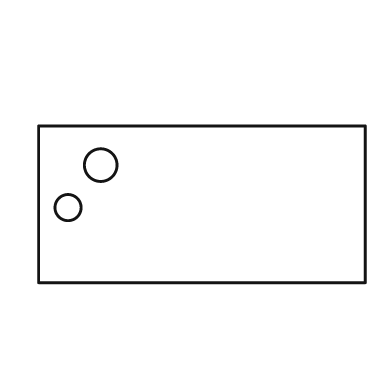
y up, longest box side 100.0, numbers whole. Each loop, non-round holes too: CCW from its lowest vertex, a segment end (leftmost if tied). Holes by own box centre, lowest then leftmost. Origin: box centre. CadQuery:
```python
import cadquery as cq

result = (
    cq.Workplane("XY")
    .moveTo(-50.0, -24.0)
    .lineTo(50.0, -24.0)
    .lineTo(50.0, 24.0)
    .lineTo(-50.0, 24.0)
    .close()
    .moveTo(-41.0, -1.0)
    .circle(4.0)
    .moveTo(-31.0, 12.0)
    .circle(5.0)
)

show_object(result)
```